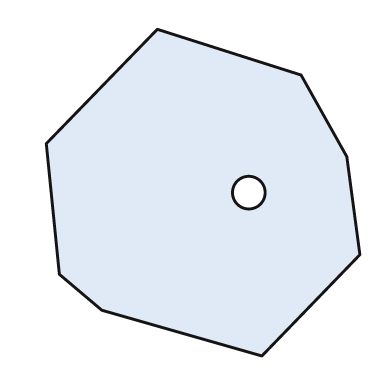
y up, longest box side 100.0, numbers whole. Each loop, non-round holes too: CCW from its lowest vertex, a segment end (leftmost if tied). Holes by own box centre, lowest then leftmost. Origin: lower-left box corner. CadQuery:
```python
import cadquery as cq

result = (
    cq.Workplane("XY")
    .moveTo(66.0, 0.0)
    .lineTo(96.0, 31.0)
    .lineTo(92.0, 61.0)
    .lineTo(78.0, 86.0)
    .lineTo(34.0, 100.0)
    .lineTo(0.0, 65.0)
    .lineTo(4.0, 25.0)
    .lineTo(17.0, 14.0)
    .close()
    .moveTo(62.0, 50.0)
    .circle(5.0)
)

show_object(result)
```